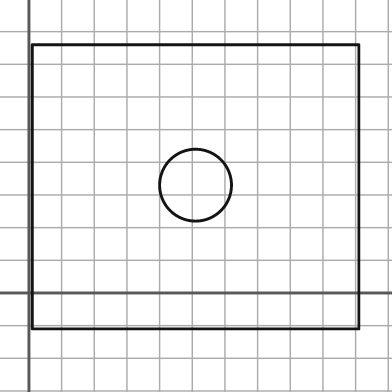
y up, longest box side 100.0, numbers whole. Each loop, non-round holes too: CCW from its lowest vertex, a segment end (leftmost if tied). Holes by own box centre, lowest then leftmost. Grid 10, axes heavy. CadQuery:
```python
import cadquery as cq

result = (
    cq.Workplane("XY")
    .moveTo(1.0, -11.0)
    .lineTo(101.0, -11.0)
    .lineTo(101.0, 76.0)
    .lineTo(1.0, 76.0)
    .close()
    .moveTo(51.0, 33.0)
    .circle(11.0)
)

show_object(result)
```